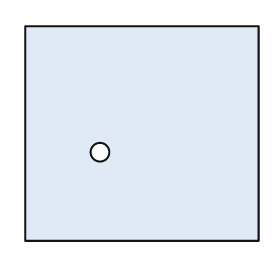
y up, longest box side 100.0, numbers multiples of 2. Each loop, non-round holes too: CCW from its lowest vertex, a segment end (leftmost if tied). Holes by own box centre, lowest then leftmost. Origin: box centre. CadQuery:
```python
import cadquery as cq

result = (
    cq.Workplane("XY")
    .moveTo(-50.0, -46.0)
    .lineTo(50.0, -46.0)
    .lineTo(50.0, 46.0)
    .lineTo(-50.0, 46.0)
    .close()
    .moveTo(-18.0, -8.0)
    .circle(4.0)
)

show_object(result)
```